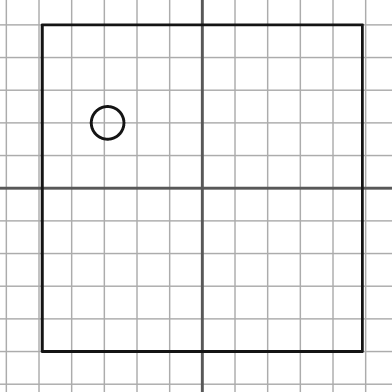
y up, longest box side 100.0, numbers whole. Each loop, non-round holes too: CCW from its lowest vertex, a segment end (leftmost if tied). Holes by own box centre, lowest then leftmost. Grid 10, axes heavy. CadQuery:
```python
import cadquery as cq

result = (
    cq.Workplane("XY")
    .moveTo(-49.0, -50.0)
    .lineTo(49.0, -50.0)
    .lineTo(49.0, 50.0)
    .lineTo(-49.0, 50.0)
    .close()
    .moveTo(-29.0, 20.0)
    .circle(5.0)
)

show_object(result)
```